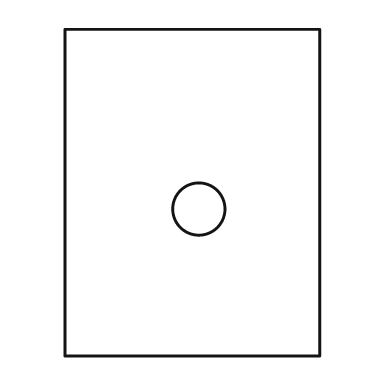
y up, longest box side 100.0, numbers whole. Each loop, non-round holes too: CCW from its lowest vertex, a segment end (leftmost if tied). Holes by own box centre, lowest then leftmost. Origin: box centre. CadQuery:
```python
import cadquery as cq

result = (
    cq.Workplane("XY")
    .moveTo(-39.0, -50.0)
    .lineTo(39.0, -50.0)
    .lineTo(39.0, 50.0)
    .lineTo(-39.0, 50.0)
    .close()
    .moveTo(2.0, -5.0)
    .circle(8.0)
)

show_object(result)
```